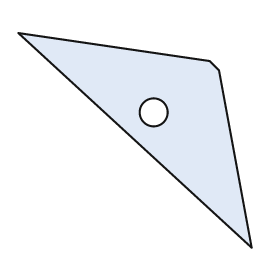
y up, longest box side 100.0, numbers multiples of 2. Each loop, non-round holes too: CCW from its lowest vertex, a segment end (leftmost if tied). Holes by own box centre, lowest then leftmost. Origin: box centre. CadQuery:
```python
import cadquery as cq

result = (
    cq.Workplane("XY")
    .moveTo(50.0, -46.0)
    .lineTo(36.0, 30.0)
    .lineTo(32.0, 34.0)
    .lineTo(-50.0, 46.0)
    .close()
    .moveTo(8.0, 12.0)
    .circle(6.0)
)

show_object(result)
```